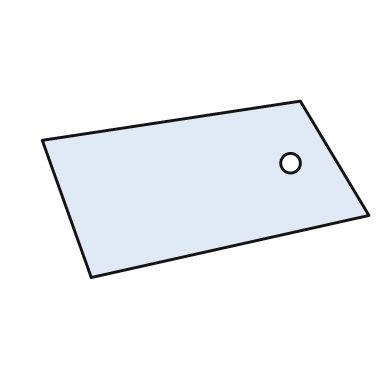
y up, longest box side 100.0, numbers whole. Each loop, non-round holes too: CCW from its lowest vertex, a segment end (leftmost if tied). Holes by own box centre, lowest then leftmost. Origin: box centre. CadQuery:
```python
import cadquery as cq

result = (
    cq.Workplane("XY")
    .moveTo(-35.0, -27.0)
    .lineTo(50.0, -8.0)
    .lineTo(29.0, 27.0)
    .lineTo(-50.0, 15.0)
    .close()
    .moveTo(26.0, 8.0)
    .circle(3.0)
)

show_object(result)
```